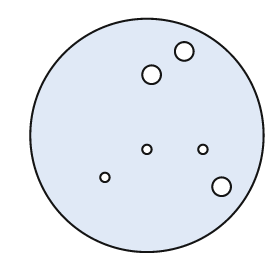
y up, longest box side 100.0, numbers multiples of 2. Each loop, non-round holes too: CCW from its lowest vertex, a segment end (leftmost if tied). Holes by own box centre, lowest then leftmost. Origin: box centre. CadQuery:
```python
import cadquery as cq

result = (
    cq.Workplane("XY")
    .moveTo(0.0, 0.0)
    .circle(50.0)
    .moveTo(32.0, -22.0)
    .circle(4.0)
    .moveTo(-18.0, -18.0)
    .circle(2.0)
    .moveTo(0.0, -6.0)
    .circle(2.0)
    .moveTo(24.0, -6.0)
    .circle(2.0)
    .moveTo(2.0, 26.0)
    .circle(4.0)
    .moveTo(16.0, 36.0)
    .circle(4.0)
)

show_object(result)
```